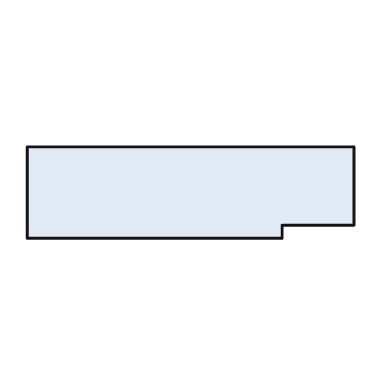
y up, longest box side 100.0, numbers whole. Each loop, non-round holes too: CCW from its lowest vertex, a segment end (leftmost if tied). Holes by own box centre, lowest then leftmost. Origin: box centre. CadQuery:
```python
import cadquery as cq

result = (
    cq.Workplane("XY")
    .moveTo(-50.0, -14.0)
    .lineTo(28.0, -14.0)
    .lineTo(28.0, -10.0)
    .lineTo(50.0, -10.0)
    .lineTo(50.0, 14.0)
    .lineTo(-50.0, 14.0)
    .close()
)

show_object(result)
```